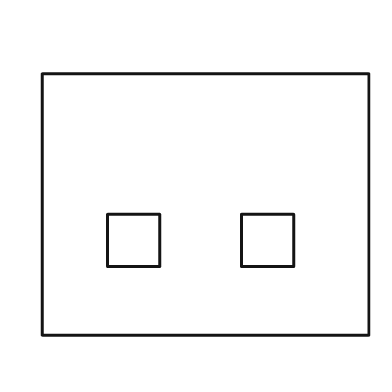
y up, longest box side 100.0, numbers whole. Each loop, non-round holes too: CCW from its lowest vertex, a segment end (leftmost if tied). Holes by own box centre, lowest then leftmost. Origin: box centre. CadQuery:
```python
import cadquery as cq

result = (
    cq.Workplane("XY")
    .moveTo(-50.0, -40.0)
    .lineTo(50.0, -40.0)
    .lineTo(50.0, 40.0)
    .lineTo(-50.0, 40.0)
    .close()
    .moveTo(-30.0, -19.0)
    .lineTo(-14.0, -19.0)
    .lineTo(-14.0, -3.0)
    .lineTo(-30.0, -3.0)
    .close()
    .moveTo(11.0, -19.0)
    .lineTo(27.0, -19.0)
    .lineTo(27.0, -3.0)
    .lineTo(11.0, -3.0)
    .close()
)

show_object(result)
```